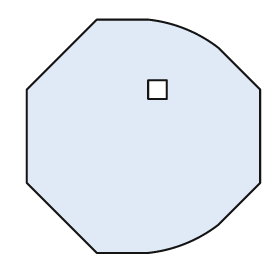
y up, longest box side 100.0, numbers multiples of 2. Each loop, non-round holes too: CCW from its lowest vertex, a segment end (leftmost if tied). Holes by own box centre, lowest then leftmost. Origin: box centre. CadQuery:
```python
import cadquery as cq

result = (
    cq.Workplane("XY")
    .moveTo(-20.0, -50.0)
    .lineTo(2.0, -50.0)
    .threePointArc((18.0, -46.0), (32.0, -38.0))
    .lineTo(50.0, -20.0)
    .lineTo(50.0, 20.0)
    .lineTo(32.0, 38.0)
    .threePointArc((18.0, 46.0), (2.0, 50.0))
    .lineTo(-20.0, 50.0)
    .lineTo(-50.0, 20.0)
    .lineTo(-50.0, -20.0)
    .close()
    .moveTo(2.0, 16.0)
    .lineTo(10.0, 16.0)
    .lineTo(10.0, 24.0)
    .lineTo(2.0, 24.0)
    .close()
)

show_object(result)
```